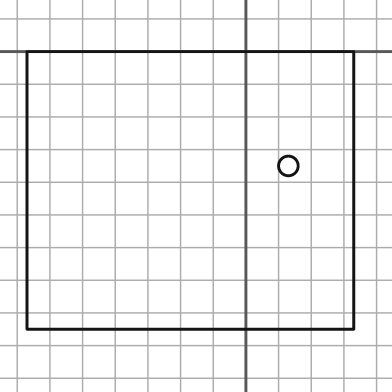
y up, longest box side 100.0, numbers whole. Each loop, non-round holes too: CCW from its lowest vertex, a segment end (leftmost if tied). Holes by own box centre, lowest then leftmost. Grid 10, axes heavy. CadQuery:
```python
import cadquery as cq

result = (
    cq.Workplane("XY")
    .moveTo(-67.0, -85.0)
    .lineTo(33.0, -85.0)
    .lineTo(33.0, 0.0)
    .lineTo(-67.0, 0.0)
    .close()
    .moveTo(13.0, -35.0)
    .circle(3.0)
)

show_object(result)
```